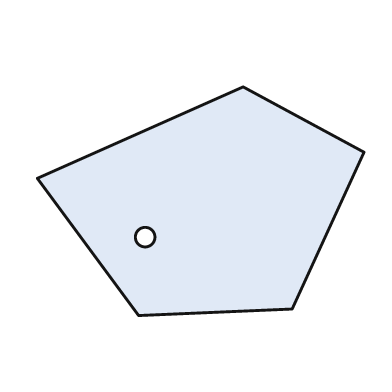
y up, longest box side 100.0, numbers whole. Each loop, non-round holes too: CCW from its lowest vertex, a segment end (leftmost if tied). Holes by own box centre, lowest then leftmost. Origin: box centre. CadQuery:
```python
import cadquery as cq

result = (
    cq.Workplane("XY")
    .moveTo(-19.0, -35.0)
    .lineTo(28.0, -33.0)
    .lineTo(50.0, 15.0)
    .lineTo(13.0, 35.0)
    .lineTo(-50.0, 7.0)
    .close()
    .moveTo(-17.0, -11.0)
    .circle(3.0)
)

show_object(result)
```